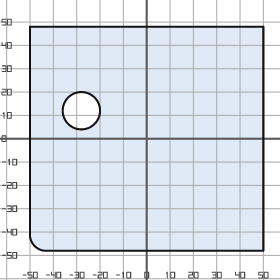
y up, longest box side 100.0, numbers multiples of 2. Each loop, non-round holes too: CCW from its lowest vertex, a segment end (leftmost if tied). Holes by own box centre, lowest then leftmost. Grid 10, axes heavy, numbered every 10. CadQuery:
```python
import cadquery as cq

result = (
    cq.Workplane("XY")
    .moveTo(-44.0, -48.0)
    .lineTo(50.0, -48.0)
    .lineTo(50.0, 48.0)
    .lineTo(-50.0, 48.0)
    .lineTo(-50.0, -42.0)
    .threePointArc((-48.0, -46.0), (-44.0, -48.0))
    .close()
    .moveTo(-28.0, 12.0)
    .circle(8.0)
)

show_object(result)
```